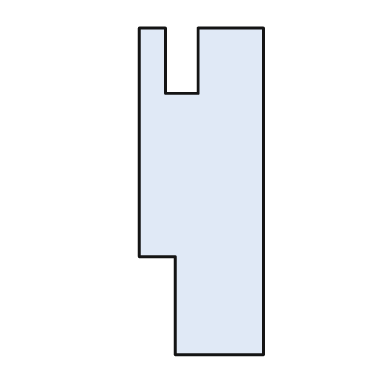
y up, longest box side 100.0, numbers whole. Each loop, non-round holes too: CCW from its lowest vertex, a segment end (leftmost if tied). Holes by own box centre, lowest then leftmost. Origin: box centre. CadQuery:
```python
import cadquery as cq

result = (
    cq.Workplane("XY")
    .moveTo(-8.0, -50.0)
    .lineTo(19.0, -50.0)
    .lineTo(19.0, 50.0)
    .lineTo(-1.0, 50.0)
    .lineTo(-1.0, 30.0)
    .lineTo(-11.0, 30.0)
    .lineTo(-11.0, 50.0)
    .lineTo(-19.0, 50.0)
    .lineTo(-19.0, -20.0)
    .lineTo(-8.0, -20.0)
    .close()
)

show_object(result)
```